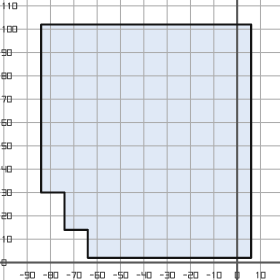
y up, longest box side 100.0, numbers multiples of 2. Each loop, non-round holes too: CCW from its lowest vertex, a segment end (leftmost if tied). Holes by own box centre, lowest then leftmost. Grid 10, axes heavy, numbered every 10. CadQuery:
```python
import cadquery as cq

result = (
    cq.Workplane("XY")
    .moveTo(-64.0, 2.0)
    .lineTo(6.0, 2.0)
    .lineTo(6.0, 102.0)
    .lineTo(-84.0, 102.0)
    .lineTo(-84.0, 30.0)
    .lineTo(-74.0, 30.0)
    .lineTo(-74.0, 14.0)
    .lineTo(-64.0, 14.0)
    .close()
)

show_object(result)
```